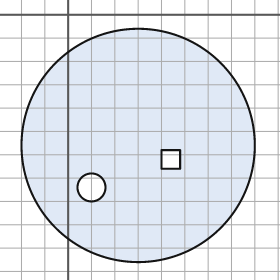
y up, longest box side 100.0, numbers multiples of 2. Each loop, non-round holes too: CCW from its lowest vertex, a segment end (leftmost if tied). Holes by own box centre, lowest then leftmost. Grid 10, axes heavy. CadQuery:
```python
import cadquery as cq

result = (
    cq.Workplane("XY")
    .moveTo(30.0, -56.0)
    .circle(50.0)
    .moveTo(10.0, -74.0)
    .circle(6.0)
    .moveTo(40.0, -66.0)
    .lineTo(48.0, -66.0)
    .lineTo(48.0, -58.0)
    .lineTo(40.0, -58.0)
    .close()
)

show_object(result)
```